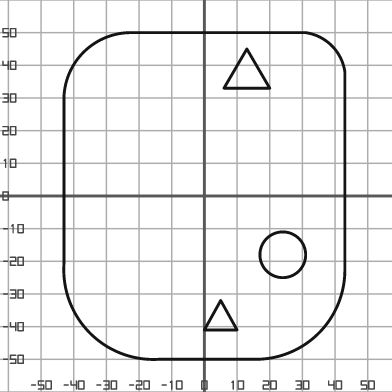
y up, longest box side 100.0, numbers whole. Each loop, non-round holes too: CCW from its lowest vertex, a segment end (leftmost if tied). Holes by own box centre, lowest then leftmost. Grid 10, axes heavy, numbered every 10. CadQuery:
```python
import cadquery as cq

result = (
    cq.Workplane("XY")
    .moveTo(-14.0, -50.0)
    .lineTo(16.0, -50.0)
    .threePointArc((35.0, -42.0), (43.0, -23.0))
    .lineTo(43.0, 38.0)
    .threePointArc((39.0, 46.0), (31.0, 50.0))
    .lineTo(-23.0, 50.0)
    .threePointArc((-37.0, 44.0), (-43.0, 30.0))
    .lineTo(-43.0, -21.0)
    .threePointArc((-35.0, -42.0), (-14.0, -50.0))
    .close()
    .moveTo(0.0, -41.0)
    .lineTo(10.0, -41.0)
    .lineTo(5.0, -32.0)
    .close()
    .moveTo(24.0, -18.0)
    .circle(7.0)
    .moveTo(6.0, 33.0)
    .lineTo(20.0, 33.0)
    .lineTo(13.0, 45.0)
    .close()
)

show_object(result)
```